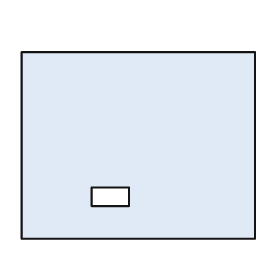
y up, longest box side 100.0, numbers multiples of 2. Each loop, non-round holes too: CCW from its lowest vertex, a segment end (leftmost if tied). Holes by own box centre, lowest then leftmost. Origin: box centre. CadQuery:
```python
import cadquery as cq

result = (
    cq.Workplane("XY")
    .moveTo(-50.0, -40.0)
    .lineTo(50.0, -40.0)
    .lineTo(50.0, 40.0)
    .lineTo(-50.0, 40.0)
    .close()
    .moveTo(-20.0, -26.0)
    .lineTo(-4.0, -26.0)
    .lineTo(-4.0, -18.0)
    .lineTo(-20.0, -18.0)
    .close()
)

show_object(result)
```